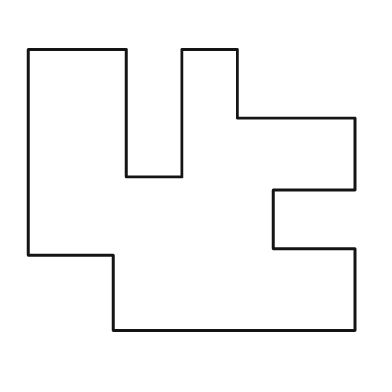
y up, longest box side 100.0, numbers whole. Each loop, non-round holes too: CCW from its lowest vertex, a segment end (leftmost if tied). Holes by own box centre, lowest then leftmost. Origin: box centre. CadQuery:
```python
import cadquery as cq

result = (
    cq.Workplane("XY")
    .moveTo(-24.0, -43.0)
    .lineTo(50.0, -43.0)
    .lineTo(50.0, -18.0)
    .lineTo(25.0, -18.0)
    .lineTo(25.0, 0.0)
    .lineTo(50.0, 0.0)
    .lineTo(50.0, 22.0)
    .lineTo(14.0, 22.0)
    .lineTo(14.0, 43.0)
    .lineTo(-3.0, 43.0)
    .lineTo(-3.0, 4.0)
    .lineTo(-20.0, 4.0)
    .lineTo(-20.0, 43.0)
    .lineTo(-50.0, 43.0)
    .lineTo(-50.0, -20.0)
    .lineTo(-24.0, -20.0)
    .close()
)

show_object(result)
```